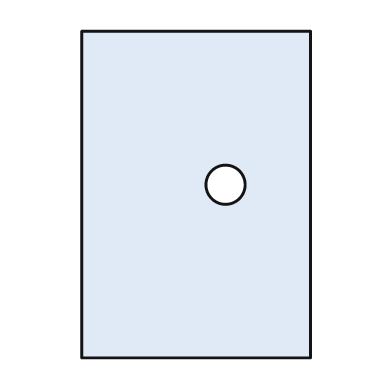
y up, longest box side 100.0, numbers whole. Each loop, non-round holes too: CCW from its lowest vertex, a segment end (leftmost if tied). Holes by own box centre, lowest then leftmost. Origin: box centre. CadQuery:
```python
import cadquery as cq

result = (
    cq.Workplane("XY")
    .moveTo(-35.0, -50.0)
    .lineTo(35.0, -50.0)
    .lineTo(35.0, 50.0)
    .lineTo(-35.0, 50.0)
    .close()
    .moveTo(9.0, 3.0)
    .circle(6.0)
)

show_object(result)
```